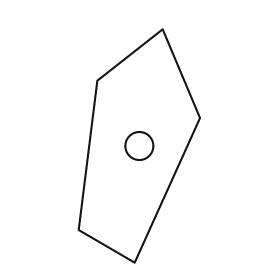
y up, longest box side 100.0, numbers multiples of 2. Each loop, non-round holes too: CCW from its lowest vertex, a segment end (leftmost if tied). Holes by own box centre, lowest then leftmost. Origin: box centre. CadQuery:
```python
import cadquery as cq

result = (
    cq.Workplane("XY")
    .moveTo(-2.0, -50.0)
    .lineTo(26.0, 12.0)
    .lineTo(10.0, 50.0)
    .lineTo(-18.0, 28.0)
    .lineTo(-26.0, -36.0)
    .close()
    .moveTo(0.0, 0.0)
    .circle(6.0)
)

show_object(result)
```